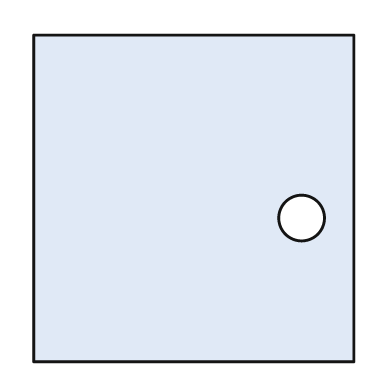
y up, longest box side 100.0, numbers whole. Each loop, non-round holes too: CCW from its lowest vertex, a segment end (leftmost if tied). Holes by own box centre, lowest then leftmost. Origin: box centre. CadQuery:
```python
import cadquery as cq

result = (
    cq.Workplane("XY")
    .moveTo(-49.0, -50.0)
    .lineTo(49.0, -50.0)
    .lineTo(49.0, 50.0)
    .lineTo(-49.0, 50.0)
    .close()
    .moveTo(33.0, -6.0)
    .circle(7.0)
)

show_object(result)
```